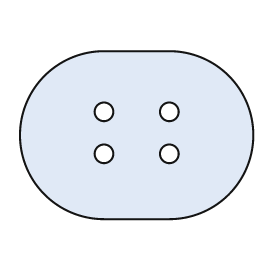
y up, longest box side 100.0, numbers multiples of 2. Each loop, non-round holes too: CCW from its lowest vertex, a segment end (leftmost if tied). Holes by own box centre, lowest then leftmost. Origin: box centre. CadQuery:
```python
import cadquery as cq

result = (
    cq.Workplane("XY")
    .moveTo(-14.0, -36.0)
    .lineTo(14.0, -36.0)
    .threePointArc((50.0, 0.0), (14.0, 36.0))
    .lineTo(-14.0, 36.0)
    .threePointArc((-50.0, 0.0), (-14.0, -36.0))
    .close()
    .moveTo(-14.0, -8.0)
    .circle(4.0)
    .moveTo(14.0, -8.0)
    .circle(4.0)
    .moveTo(-14.0, 10.0)
    .circle(4.0)
    .moveTo(14.0, 10.0)
    .circle(4.0)
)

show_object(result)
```